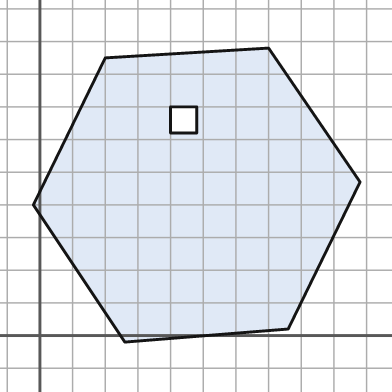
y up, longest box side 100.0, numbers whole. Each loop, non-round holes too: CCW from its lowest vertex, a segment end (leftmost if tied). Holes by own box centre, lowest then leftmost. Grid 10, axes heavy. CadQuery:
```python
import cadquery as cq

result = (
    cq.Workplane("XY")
    .moveTo(26.0, -2.0)
    .lineTo(76.0, 2.0)
    .lineTo(98.0, 47.0)
    .lineTo(70.0, 88.0)
    .lineTo(20.0, 85.0)
    .lineTo(-2.0, 40.0)
    .close()
    .moveTo(40.0, 62.0)
    .lineTo(48.0, 62.0)
    .lineTo(48.0, 70.0)
    .lineTo(40.0, 70.0)
    .close()
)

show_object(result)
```